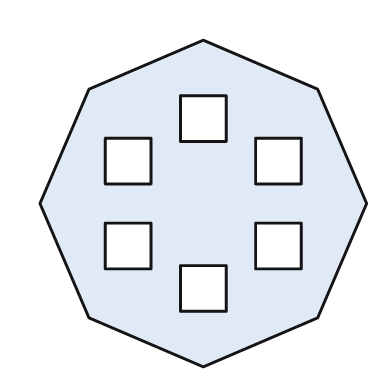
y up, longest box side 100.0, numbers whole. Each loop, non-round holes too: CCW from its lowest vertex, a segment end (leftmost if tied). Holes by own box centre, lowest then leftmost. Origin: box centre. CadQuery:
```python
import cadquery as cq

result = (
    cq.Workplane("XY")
    .moveTo(0.0, -50.0)
    .lineTo(35.0, -35.0)
    .lineTo(50.0, 0.0)
    .lineTo(35.0, 35.0)
    .lineTo(0.0, 50.0)
    .lineTo(-35.0, 35.0)
    .lineTo(-50.0, 0.0)
    .lineTo(-35.0, -35.0)
    .close()
    .moveTo(-7.0, -33.0)
    .lineTo(7.0, -33.0)
    .lineTo(7.0, -19.0)
    .lineTo(-7.0, -19.0)
    .close()
    .moveTo(-30.0, -20.0)
    .lineTo(-16.0, -20.0)
    .lineTo(-16.0, -6.0)
    .lineTo(-30.0, -6.0)
    .close()
    .moveTo(16.0, -20.0)
    .lineTo(30.0, -20.0)
    .lineTo(30.0, -6.0)
    .lineTo(16.0, -6.0)
    .close()
    .moveTo(-30.0, 6.0)
    .lineTo(-16.0, 6.0)
    .lineTo(-16.0, 20.0)
    .lineTo(-30.0, 20.0)
    .close()
    .moveTo(16.0, 6.0)
    .lineTo(30.0, 6.0)
    .lineTo(30.0, 20.0)
    .lineTo(16.0, 20.0)
    .close()
    .moveTo(-7.0, 19.0)
    .lineTo(7.0, 19.0)
    .lineTo(7.0, 33.0)
    .lineTo(-7.0, 33.0)
    .close()
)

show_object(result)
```